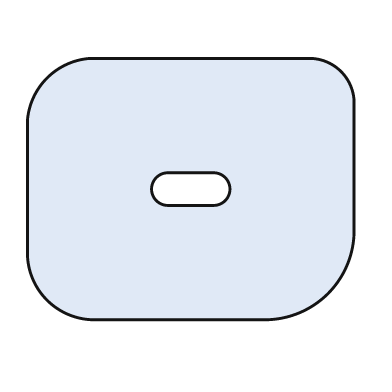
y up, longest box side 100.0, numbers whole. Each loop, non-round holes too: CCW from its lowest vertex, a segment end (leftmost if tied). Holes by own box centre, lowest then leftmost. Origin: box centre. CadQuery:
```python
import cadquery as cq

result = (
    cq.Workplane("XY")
    .moveTo(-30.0, -40.0)
    .lineTo(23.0, -40.0)
    .threePointArc((42.0, -32.0), (50.0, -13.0))
    .lineTo(50.0, 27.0)
    .threePointArc((46.0, 36.0), (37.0, 40.0))
    .lineTo(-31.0, 40.0)
    .threePointArc((-44.0, 34.0), (-50.0, 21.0))
    .lineTo(-50.0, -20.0)
    .threePointArc((-44.0, -34.0), (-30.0, -40.0))
    .close()
    .moveTo(-7.0, -5.0)
    .lineTo(7.0, -5.0)
    .threePointArc((12.0, 0.0), (7.0, 5.0))
    .lineTo(-7.0, 5.0)
    .threePointArc((-12.0, 0.0), (-7.0, -5.0))
    .close()
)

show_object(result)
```